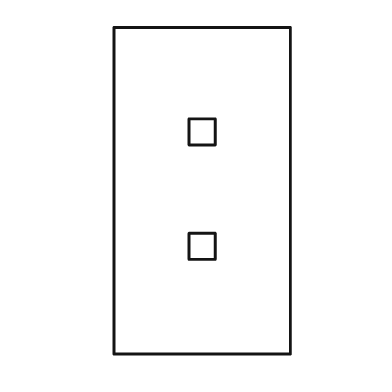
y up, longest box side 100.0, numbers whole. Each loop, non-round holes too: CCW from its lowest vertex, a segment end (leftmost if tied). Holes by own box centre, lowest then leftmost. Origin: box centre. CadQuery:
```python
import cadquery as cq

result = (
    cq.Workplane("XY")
    .moveTo(-27.0, -50.0)
    .lineTo(27.0, -50.0)
    .lineTo(27.0, 50.0)
    .lineTo(-27.0, 50.0)
    .close()
    .moveTo(-4.0, -21.0)
    .lineTo(4.0, -21.0)
    .lineTo(4.0, -13.0)
    .lineTo(-4.0, -13.0)
    .close()
    .moveTo(-4.0, 14.0)
    .lineTo(4.0, 14.0)
    .lineTo(4.0, 22.0)
    .lineTo(-4.0, 22.0)
    .close()
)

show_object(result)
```